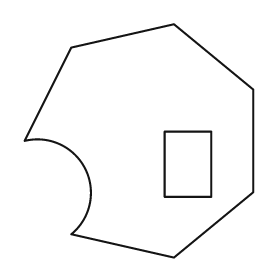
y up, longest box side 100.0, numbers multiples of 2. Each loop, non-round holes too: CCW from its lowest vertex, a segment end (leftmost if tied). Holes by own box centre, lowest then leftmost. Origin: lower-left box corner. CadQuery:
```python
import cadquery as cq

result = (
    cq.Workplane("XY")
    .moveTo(64.0, 0.0)
    .lineTo(98.0, 28.0)
    .lineTo(98.0, 72.0)
    .lineTo(64.0, 100.0)
    .lineTo(20.0, 90.0)
    .lineTo(0.0, 50.0)
    .threePointArc((26.0, 38.0), (20.0, 10.0))
    .close()
    .moveTo(60.0, 26.0)
    .lineTo(80.0, 26.0)
    .lineTo(80.0, 54.0)
    .lineTo(60.0, 54.0)
    .close()
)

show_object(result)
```